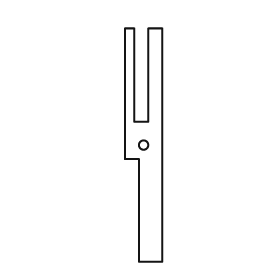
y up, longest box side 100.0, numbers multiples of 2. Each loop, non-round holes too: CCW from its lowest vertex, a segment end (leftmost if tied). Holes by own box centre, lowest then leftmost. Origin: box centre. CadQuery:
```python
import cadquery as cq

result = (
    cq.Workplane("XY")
    .moveTo(-2.0, -50.0)
    .lineTo(8.0, -50.0)
    .lineTo(8.0, 50.0)
    .lineTo(2.0, 50.0)
    .lineTo(2.0, 10.0)
    .lineTo(-4.0, 10.0)
    .lineTo(-4.0, 50.0)
    .lineTo(-8.0, 50.0)
    .lineTo(-8.0, -6.0)
    .lineTo(-2.0, -6.0)
    .close()
    .moveTo(0.0, 0.0)
    .circle(2.0)
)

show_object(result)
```